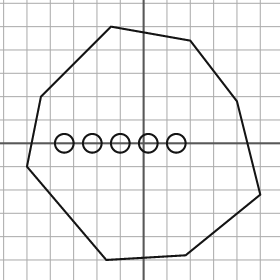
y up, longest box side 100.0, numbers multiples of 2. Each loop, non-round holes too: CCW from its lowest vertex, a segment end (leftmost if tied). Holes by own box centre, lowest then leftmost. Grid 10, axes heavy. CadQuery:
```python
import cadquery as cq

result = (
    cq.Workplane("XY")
    .moveTo(-16.0, -50.0)
    .lineTo(18.0, -48.0)
    .lineTo(50.0, -22.0)
    .lineTo(40.0, 18.0)
    .lineTo(20.0, 44.0)
    .lineTo(-14.0, 50.0)
    .lineTo(-44.0, 20.0)
    .lineTo(-50.0, -10.0)
    .close()
    .moveTo(-34.0, 0.0)
    .circle(4.0)
    .moveTo(-22.0, 0.0)
    .circle(4.0)
    .moveTo(-10.0, 0.0)
    .circle(4.0)
    .moveTo(2.0, 0.0)
    .circle(4.0)
    .moveTo(14.0, 0.0)
    .circle(4.0)
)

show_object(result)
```